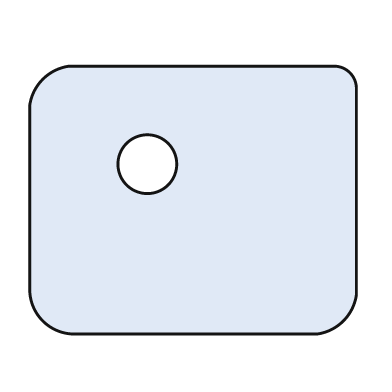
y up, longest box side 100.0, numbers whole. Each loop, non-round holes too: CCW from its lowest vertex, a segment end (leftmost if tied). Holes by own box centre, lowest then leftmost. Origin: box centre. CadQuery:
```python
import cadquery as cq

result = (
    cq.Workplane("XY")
    .moveTo(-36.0, -41.0)
    .lineTo(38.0, -41.0)
    .threePointArc((46.0, -37.0), (50.0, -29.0))
    .lineTo(50.0, 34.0)
    .threePointArc((48.0, 39.0), (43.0, 41.0))
    .lineTo(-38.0, 41.0)
    .threePointArc((-46.0, 37.0), (-50.0, 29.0))
    .lineTo(-50.0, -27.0)
    .threePointArc((-46.0, -37.0), (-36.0, -41.0))
    .close()
    .moveTo(-14.0, 11.0)
    .circle(9.0)
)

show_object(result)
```